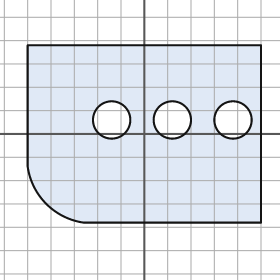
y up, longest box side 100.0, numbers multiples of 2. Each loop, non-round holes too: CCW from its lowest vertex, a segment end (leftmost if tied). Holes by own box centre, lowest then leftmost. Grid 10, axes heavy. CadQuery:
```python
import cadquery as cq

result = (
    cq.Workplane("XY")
    .moveTo(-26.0, -38.0)
    .lineTo(50.0, -38.0)
    .lineTo(50.0, 38.0)
    .lineTo(-50.0, 38.0)
    .lineTo(-50.0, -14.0)
    .threePointArc((-42.0, -30.0), (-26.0, -38.0))
    .close()
    .moveTo(-14.0, 6.0)
    .circle(8.0)
    .moveTo(12.0, 6.0)
    .circle(8.0)
    .moveTo(38.0, 6.0)
    .circle(8.0)
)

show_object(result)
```